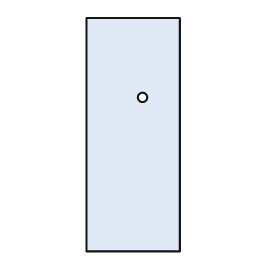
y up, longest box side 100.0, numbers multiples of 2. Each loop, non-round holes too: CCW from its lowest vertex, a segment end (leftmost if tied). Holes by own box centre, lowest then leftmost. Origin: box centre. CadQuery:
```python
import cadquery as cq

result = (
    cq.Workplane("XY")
    .moveTo(-20.0, -50.0)
    .lineTo(20.0, -50.0)
    .lineTo(20.0, 50.0)
    .lineTo(-20.0, 50.0)
    .close()
    .moveTo(4.0, 16.0)
    .circle(2.0)
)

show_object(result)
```